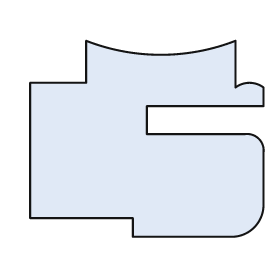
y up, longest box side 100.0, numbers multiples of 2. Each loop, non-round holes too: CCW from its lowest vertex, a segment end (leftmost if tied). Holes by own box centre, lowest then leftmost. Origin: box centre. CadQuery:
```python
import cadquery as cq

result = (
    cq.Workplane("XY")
    .moveTo(-6.0, -42.0)
    .lineTo(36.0, -42.0)
    .threePointArc((46.0, -38.0), (50.0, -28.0))
    .lineTo(50.0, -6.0)
    .threePointArc((48.0, 0.0), (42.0, 2.0))
    .lineTo(0.0, 2.0)
    .lineTo(0.0, 14.0)
    .lineTo(50.0, 14.0)
    .lineTo(50.0, 22.0)
    .threePointArc((44.0, 24.0), (38.0, 22.0))
    .lineTo(38.0, 42.0)
    .threePointArc((6.0, 36.0), (-26.0, 42.0))
    .lineTo(-26.0, 24.0)
    .lineTo(-50.0, 24.0)
    .lineTo(-50.0, -34.0)
    .lineTo(-6.0, -34.0)
    .close()
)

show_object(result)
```